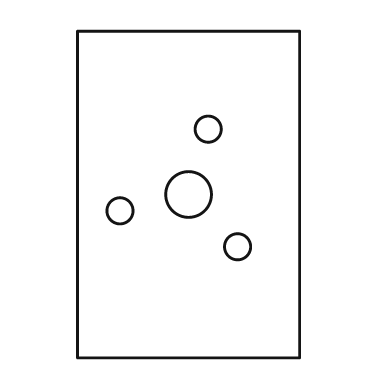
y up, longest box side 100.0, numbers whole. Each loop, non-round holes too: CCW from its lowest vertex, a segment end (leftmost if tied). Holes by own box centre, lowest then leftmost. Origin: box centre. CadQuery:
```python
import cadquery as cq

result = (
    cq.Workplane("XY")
    .moveTo(-34.0, -50.0)
    .lineTo(34.0, -50.0)
    .lineTo(34.0, 50.0)
    .lineTo(-34.0, 50.0)
    .close()
    .moveTo(15.0, -16.0)
    .circle(4.0)
    .moveTo(-21.0, -5.0)
    .circle(4.0)
    .moveTo(0.0, 0.0)
    .circle(7.0)
    .moveTo(6.0, 20.0)
    .circle(4.0)
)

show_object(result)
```